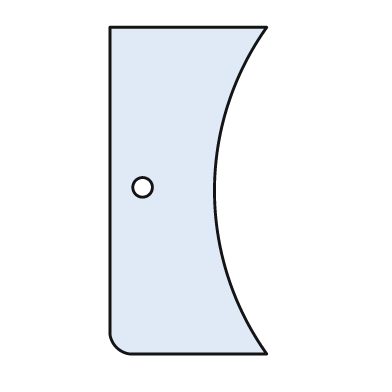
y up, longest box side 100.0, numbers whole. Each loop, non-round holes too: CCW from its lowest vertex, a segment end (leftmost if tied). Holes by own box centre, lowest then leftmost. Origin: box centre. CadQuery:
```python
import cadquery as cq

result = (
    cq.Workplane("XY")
    .moveTo(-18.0, -50.0)
    .lineTo(24.0, -50.0)
    .threePointArc((8.0, 0.0), (24.0, 50.0))
    .lineTo(-24.0, 50.0)
    .lineTo(-24.0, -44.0)
    .threePointArc((-22.0, -48.0), (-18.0, -50.0))
    .close()
    .moveTo(-14.0, 1.0)
    .circle(3.0)
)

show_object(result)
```